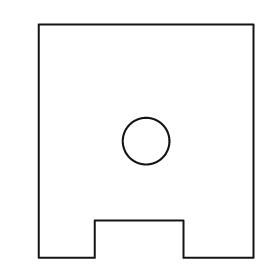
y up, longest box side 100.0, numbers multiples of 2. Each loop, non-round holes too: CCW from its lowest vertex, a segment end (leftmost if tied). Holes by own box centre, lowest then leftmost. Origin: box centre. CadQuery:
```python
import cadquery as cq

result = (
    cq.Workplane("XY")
    .moveTo(-46.0, -50.0)
    .lineTo(-22.0, -50.0)
    .lineTo(-22.0, -34.0)
    .lineTo(16.0, -34.0)
    .lineTo(16.0, -50.0)
    .lineTo(46.0, -50.0)
    .lineTo(46.0, 50.0)
    .lineTo(-46.0, 50.0)
    .close()
    .moveTo(0.0, 0.0)
    .circle(10.0)
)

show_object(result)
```